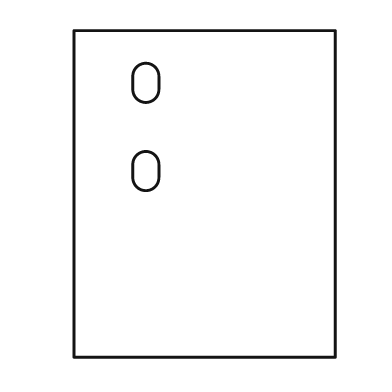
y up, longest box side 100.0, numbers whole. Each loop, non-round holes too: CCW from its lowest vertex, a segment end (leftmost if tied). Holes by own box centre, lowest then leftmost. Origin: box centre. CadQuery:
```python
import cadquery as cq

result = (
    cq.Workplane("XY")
    .moveTo(-40.0, -50.0)
    .lineTo(40.0, -50.0)
    .lineTo(40.0, 50.0)
    .lineTo(-40.0, 50.0)
    .close()
    .moveTo(-22.0, 5.0)
    .threePointArc((-18.0, 1.0), (-14.0, 5.0))
    .lineTo(-14.0, 9.0)
    .threePointArc((-18.0, 13.0), (-22.0, 9.0))
    .close()
    .moveTo(-22.0, 32.0)
    .threePointArc((-18.0, 28.0), (-14.0, 32.0))
    .lineTo(-14.0, 36.0)
    .threePointArc((-18.0, 40.0), (-22.0, 36.0))
    .close()
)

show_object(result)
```